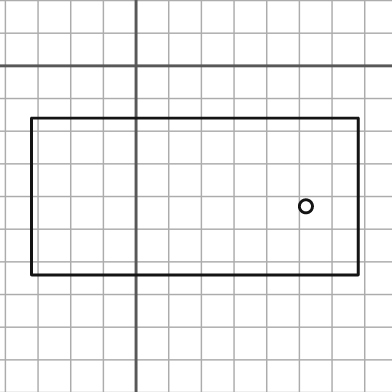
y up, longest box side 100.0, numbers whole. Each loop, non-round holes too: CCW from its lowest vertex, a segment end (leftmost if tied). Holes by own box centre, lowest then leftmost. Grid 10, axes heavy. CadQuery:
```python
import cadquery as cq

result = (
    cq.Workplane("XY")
    .moveTo(-32.0, -64.0)
    .lineTo(68.0, -64.0)
    .lineTo(68.0, -16.0)
    .lineTo(-32.0, -16.0)
    .close()
    .moveTo(52.0, -43.0)
    .circle(2.0)
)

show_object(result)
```